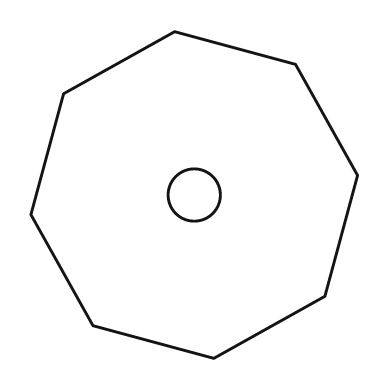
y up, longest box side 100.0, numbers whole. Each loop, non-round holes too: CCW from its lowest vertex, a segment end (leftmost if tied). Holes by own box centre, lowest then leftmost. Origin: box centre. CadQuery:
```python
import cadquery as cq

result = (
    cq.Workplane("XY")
    .moveTo(6.0, -50.0)
    .lineTo(40.0, -31.0)
    .lineTo(50.0, 6.0)
    .lineTo(31.0, 40.0)
    .lineTo(-6.0, 50.0)
    .lineTo(-40.0, 31.0)
    .lineTo(-50.0, -6.0)
    .lineTo(-31.0, -40.0)
    .close()
    .moveTo(0.0, 0.0)
    .circle(8.0)
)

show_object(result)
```